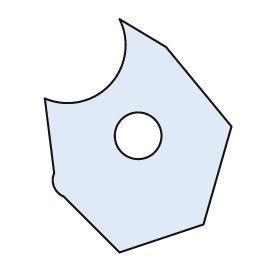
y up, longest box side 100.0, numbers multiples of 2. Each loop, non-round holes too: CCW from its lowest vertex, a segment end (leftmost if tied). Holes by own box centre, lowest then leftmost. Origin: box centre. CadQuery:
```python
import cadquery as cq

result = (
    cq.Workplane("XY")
    .moveTo(-8.0, -50.0)
    .lineTo(28.0, -38.0)
    .lineTo(40.0, 4.0)
    .lineTo(12.0, 38.0)
    .lineTo(-8.0, 50.0)
    .threePointArc((-12.0, 22.0), (-40.0, 16.0))
    .lineTo(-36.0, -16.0)
    .threePointArc((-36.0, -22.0), (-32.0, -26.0))
    .close()
    .moveTo(0.0, 0.0)
    .circle(10.0)
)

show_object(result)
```